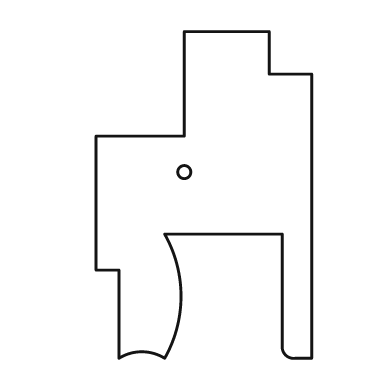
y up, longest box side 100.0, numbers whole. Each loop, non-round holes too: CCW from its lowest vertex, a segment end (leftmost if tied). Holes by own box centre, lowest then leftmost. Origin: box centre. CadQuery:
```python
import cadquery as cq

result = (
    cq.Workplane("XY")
    .moveTo(-26.0, -50.0)
    .threePointArc((-19.0, -48.0), (-12.0, -50.0))
    .threePointArc((-7.0, -31.0), (-12.0, -12.0))
    .lineTo(24.0, -12.0)
    .lineTo(24.0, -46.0)
    .threePointArc((25.0, -49.0), (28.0, -50.0))
    .lineTo(33.0, -50.0)
    .lineTo(33.0, 37.0)
    .lineTo(20.0, 37.0)
    .lineTo(20.0, 50.0)
    .lineTo(-6.0, 50.0)
    .lineTo(-6.0, 18.0)
    .lineTo(-33.0, 18.0)
    .lineTo(-33.0, -23.0)
    .lineTo(-26.0, -23.0)
    .close()
    .moveTo(-6.0, 7.0)
    .circle(2.0)
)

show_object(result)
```